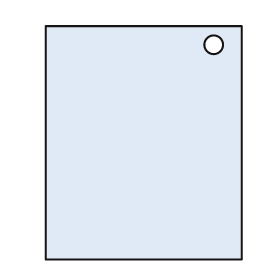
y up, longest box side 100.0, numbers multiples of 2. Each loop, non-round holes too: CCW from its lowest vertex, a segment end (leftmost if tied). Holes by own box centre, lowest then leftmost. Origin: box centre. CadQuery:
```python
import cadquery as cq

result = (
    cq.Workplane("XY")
    .moveTo(-42.0, -50.0)
    .lineTo(42.0, -50.0)
    .lineTo(42.0, 50.0)
    .lineTo(-42.0, 50.0)
    .close()
    .moveTo(30.0, 42.0)
    .circle(4.0)
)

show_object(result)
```